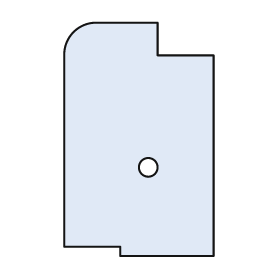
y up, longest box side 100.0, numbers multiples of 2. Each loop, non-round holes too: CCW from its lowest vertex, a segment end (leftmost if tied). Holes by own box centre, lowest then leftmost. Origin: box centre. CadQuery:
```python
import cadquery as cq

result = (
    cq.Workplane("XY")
    .moveTo(-8.0, -50.0)
    .lineTo(32.0, -50.0)
    .lineTo(32.0, 36.0)
    .lineTo(8.0, 36.0)
    .lineTo(8.0, 50.0)
    .lineTo(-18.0, 50.0)
    .threePointArc((-28.0, 46.0), (-32.0, 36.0))
    .lineTo(-32.0, -46.0)
    .lineTo(-8.0, -46.0)
    .close()
    .moveTo(4.0, -12.0)
    .circle(4.0)
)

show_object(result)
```